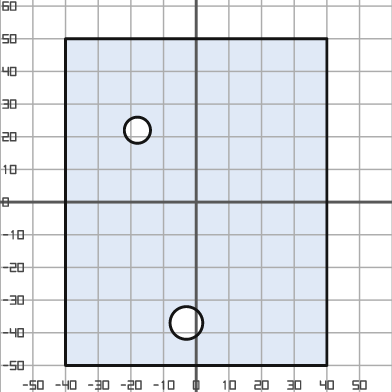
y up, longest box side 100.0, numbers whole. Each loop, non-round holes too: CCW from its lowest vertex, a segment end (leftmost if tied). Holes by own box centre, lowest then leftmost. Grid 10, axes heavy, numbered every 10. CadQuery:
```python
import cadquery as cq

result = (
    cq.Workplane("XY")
    .moveTo(-40.0, -50.0)
    .lineTo(40.0, -50.0)
    .lineTo(40.0, 50.0)
    .lineTo(-40.0, 50.0)
    .close()
    .moveTo(-3.0, -37.0)
    .circle(5.0)
    .moveTo(-18.0, 22.0)
    .circle(4.0)
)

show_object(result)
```